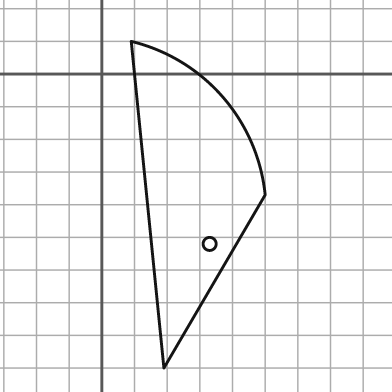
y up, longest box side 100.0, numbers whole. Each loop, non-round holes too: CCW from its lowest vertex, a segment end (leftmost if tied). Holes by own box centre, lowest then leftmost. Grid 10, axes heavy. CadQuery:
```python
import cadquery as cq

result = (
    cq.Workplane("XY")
    .moveTo(19.0, -90.0)
    .lineTo(50.0, -37.0)
    .threePointArc((37.0, -7.0), (9.0, 10.0))
    .close()
    .moveTo(33.0, -52.0)
    .circle(2.0)
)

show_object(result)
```